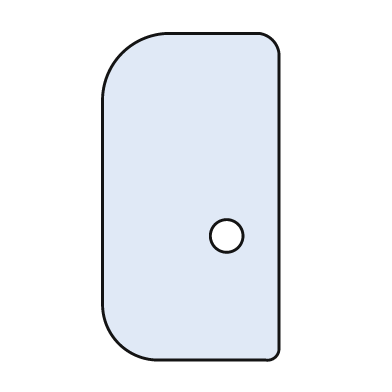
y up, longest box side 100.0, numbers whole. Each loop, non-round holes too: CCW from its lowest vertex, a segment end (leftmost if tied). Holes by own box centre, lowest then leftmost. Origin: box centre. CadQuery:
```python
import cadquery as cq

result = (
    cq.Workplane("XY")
    .moveTo(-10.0, -50.0)
    .lineTo(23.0, -50.0)
    .threePointArc((26.0, -49.0), (27.0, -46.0))
    .lineTo(27.0, 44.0)
    .threePointArc((25.0, 48.0), (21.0, 50.0))
    .lineTo(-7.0, 50.0)
    .threePointArc((-21.0, 44.0), (-27.0, 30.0))
    .lineTo(-27.0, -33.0)
    .threePointArc((-22.0, -45.0), (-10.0, -50.0))
    .close()
    .moveTo(11.0, -12.0)
    .circle(5.0)
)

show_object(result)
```